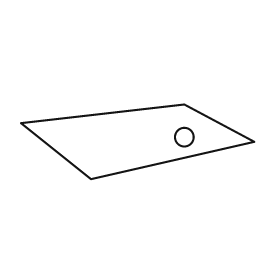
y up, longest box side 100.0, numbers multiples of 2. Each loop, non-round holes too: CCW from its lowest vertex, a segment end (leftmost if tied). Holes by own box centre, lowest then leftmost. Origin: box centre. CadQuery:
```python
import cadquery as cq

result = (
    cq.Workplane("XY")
    .moveTo(-20.0, -16.0)
    .lineTo(50.0, 0.0)
    .lineTo(20.0, 16.0)
    .lineTo(-50.0, 8.0)
    .close()
    .moveTo(20.0, 2.0)
    .circle(4.0)
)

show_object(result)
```